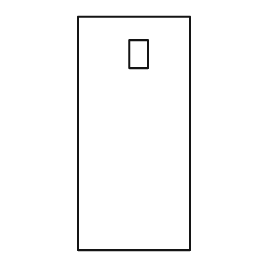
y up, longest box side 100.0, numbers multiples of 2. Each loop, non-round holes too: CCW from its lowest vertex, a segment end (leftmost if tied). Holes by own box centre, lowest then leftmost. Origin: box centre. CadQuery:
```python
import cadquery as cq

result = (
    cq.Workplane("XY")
    .moveTo(-24.0, -50.0)
    .lineTo(24.0, -50.0)
    .lineTo(24.0, 50.0)
    .lineTo(-24.0, 50.0)
    .close()
    .moveTo(-2.0, 28.0)
    .lineTo(6.0, 28.0)
    .lineTo(6.0, 40.0)
    .lineTo(-2.0, 40.0)
    .close()
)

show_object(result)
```